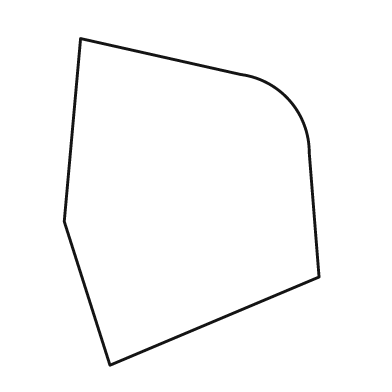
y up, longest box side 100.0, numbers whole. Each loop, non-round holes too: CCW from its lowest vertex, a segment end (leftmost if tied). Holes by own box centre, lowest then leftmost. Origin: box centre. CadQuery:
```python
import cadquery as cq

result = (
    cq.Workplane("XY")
    .moveTo(-25.0, -50.0)
    .lineTo(39.0, -23.0)
    .lineTo(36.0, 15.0)
    .threePointArc((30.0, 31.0), (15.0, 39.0))
    .lineTo(-34.0, 50.0)
    .lineTo(-39.0, -6.0)
    .close()
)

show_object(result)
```